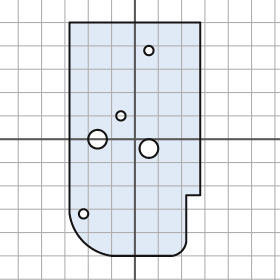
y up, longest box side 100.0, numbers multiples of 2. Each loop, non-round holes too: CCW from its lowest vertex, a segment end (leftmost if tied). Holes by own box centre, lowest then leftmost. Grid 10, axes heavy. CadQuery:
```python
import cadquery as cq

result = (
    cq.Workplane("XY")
    .moveTo(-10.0, -50.0)
    .lineTo(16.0, -50.0)
    .threePointArc((20.0, -48.0), (22.0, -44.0))
    .lineTo(22.0, -24.0)
    .lineTo(28.0, -24.0)
    .lineTo(28.0, 50.0)
    .lineTo(-28.0, 50.0)
    .lineTo(-28.0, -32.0)
    .threePointArc((-22.0, -44.0), (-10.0, -50.0))
    .close()
    .moveTo(-22.0, -32.0)
    .circle(2.0)
    .moveTo(6.0, -4.0)
    .circle(4.0)
    .moveTo(-16.0, 0.0)
    .circle(4.0)
    .moveTo(-6.0, 10.0)
    .circle(2.0)
    .moveTo(6.0, 38.0)
    .circle(2.0)
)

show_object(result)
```